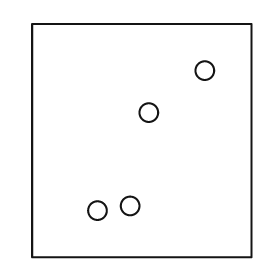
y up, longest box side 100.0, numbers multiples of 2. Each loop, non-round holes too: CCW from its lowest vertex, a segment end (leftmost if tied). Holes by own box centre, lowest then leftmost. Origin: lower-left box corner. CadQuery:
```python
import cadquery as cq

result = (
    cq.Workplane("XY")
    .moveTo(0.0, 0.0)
    .lineTo(94.0, 0.0)
    .lineTo(94.0, 100.0)
    .lineTo(0.0, 100.0)
    .close()
    .moveTo(28.0, 20.0)
    .circle(4.0)
    .moveTo(42.0, 22.0)
    .circle(4.0)
    .moveTo(50.0, 62.0)
    .circle(4.0)
    .moveTo(74.0, 80.0)
    .circle(4.0)
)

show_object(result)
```